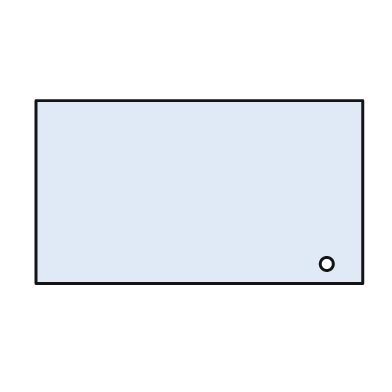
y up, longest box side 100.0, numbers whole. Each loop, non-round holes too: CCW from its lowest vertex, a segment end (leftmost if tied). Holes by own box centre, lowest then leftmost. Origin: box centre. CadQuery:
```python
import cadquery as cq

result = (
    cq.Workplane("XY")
    .moveTo(-50.0, -28.0)
    .lineTo(50.0, -28.0)
    .lineTo(50.0, 28.0)
    .lineTo(-50.0, 28.0)
    .close()
    .moveTo(39.0, -22.0)
    .circle(2.0)
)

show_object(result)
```